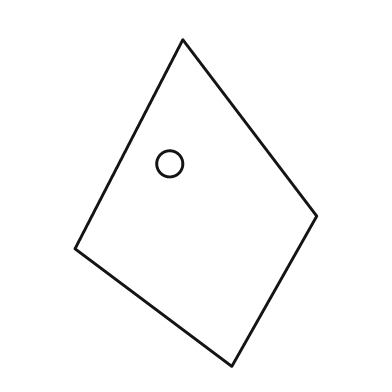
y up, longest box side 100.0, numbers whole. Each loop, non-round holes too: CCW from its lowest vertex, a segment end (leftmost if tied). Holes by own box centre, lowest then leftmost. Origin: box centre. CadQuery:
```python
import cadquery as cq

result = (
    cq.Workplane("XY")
    .moveTo(11.0, -50.0)
    .lineTo(37.0, -4.0)
    .lineTo(-4.0, 50.0)
    .lineTo(-37.0, -14.0)
    .close()
    .moveTo(-8.0, 12.0)
    .circle(4.0)
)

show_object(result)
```